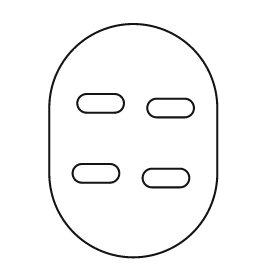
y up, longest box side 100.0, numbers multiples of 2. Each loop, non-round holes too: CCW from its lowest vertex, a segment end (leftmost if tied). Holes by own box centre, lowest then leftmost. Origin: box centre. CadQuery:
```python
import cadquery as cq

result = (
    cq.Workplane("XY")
    .moveTo(-36.0, -14.0)
    .threePointArc((0.0, -50.0), (36.0, -14.0))
    .lineTo(36.0, 14.0)
    .threePointArc((0.0, 50.0), (-36.0, 14.0))
    .close()
    .moveTo(8.0, -20.0)
    .lineTo(20.0, -20.0)
    .threePointArc((24.0, -16.0), (20.0, -12.0))
    .lineTo(8.0, -12.0)
    .threePointArc((4.0, -16.0), (8.0, -20.0))
    .close()
    .moveTo(-22.0, -18.0)
    .lineTo(-10.0, -18.0)
    .threePointArc((-6.0, -14.0), (-10.0, -10.0))
    .lineTo(-22.0, -10.0)
    .threePointArc((-26.0, -14.0), (-22.0, -18.0))
    .close()
    .moveTo(10.0, 10.0)
    .lineTo(22.0, 10.0)
    .threePointArc((26.0, 14.0), (22.0, 18.0))
    .lineTo(10.0, 18.0)
    .threePointArc((6.0, 14.0), (10.0, 10.0))
    .close()
    .moveTo(-20.0, 12.0)
    .lineTo(-8.0, 12.0)
    .threePointArc((-4.0, 16.0), (-8.0, 20.0))
    .lineTo(-20.0, 20.0)
    .threePointArc((-24.0, 16.0), (-20.0, 12.0))
    .close()
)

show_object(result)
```